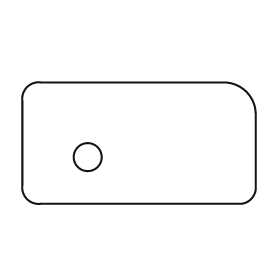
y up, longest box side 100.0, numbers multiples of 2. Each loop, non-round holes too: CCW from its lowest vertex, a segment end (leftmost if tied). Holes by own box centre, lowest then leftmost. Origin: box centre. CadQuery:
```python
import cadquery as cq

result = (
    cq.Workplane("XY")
    .moveTo(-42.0, -26.0)
    .lineTo(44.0, -26.0)
    .threePointArc((48.0, -24.0), (50.0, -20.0))
    .lineTo(50.0, 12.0)
    .threePointArc((46.0, 22.0), (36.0, 26.0))
    .lineTo(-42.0, 26.0)
    .threePointArc((-48.0, 24.0), (-50.0, 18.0))
    .lineTo(-50.0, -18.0)
    .threePointArc((-48.0, -24.0), (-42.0, -26.0))
    .close()
    .moveTo(-22.0, -6.0)
    .circle(6.0)
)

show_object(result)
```